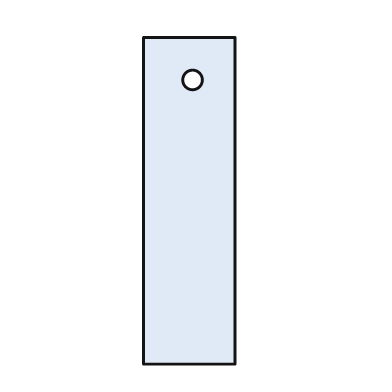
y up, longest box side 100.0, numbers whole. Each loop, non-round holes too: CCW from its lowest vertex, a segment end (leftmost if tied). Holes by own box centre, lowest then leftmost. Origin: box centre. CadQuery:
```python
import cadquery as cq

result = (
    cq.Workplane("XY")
    .moveTo(-14.0, -50.0)
    .lineTo(14.0, -50.0)
    .lineTo(14.0, 50.0)
    .lineTo(-14.0, 50.0)
    .close()
    .moveTo(1.0, 37.0)
    .circle(3.0)
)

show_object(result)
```